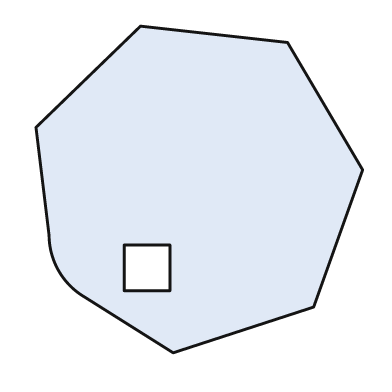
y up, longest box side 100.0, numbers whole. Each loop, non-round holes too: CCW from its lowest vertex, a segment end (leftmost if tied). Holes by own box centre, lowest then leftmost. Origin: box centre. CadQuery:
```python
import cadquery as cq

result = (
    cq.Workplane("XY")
    .moveTo(-8.0, -50.0)
    .lineTo(35.0, -36.0)
    .lineTo(50.0, 6.0)
    .lineTo(27.0, 45.0)
    .lineTo(-18.0, 50.0)
    .lineTo(-50.0, 19.0)
    .lineTo(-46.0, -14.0)
    .threePointArc((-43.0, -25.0), (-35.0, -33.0))
    .close()
    .moveTo(-23.0, -31.0)
    .lineTo(-9.0, -31.0)
    .lineTo(-9.0, -17.0)
    .lineTo(-23.0, -17.0)
    .close()
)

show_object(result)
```